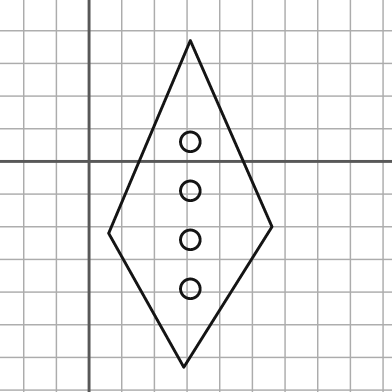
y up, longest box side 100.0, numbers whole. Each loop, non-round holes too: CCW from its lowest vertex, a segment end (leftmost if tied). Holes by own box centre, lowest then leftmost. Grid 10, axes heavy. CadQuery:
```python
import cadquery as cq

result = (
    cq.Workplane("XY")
    .moveTo(29.0, -63.0)
    .lineTo(56.0, -20.0)
    .lineTo(31.0, 37.0)
    .lineTo(6.0, -22.0)
    .close()
    .moveTo(31.0, -39.0)
    .circle(3.0)
    .moveTo(31.0, -24.0)
    .circle(3.0)
    .moveTo(31.0, -9.0)
    .circle(3.0)
    .moveTo(31.0, 6.0)
    .circle(3.0)
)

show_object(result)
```